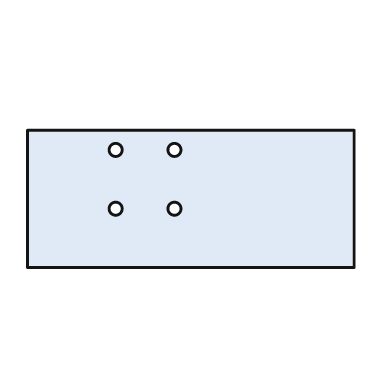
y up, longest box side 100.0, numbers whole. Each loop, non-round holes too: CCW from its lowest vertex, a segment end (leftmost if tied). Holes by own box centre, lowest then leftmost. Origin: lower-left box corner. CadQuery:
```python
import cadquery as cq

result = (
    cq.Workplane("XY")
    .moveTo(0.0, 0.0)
    .lineTo(100.0, 0.0)
    .lineTo(100.0, 42.0)
    .lineTo(0.0, 42.0)
    .close()
    .moveTo(27.0, 18.0)
    .circle(2.0)
    .moveTo(45.0, 18.0)
    .circle(2.0)
    .moveTo(27.0, 36.0)
    .circle(2.0)
    .moveTo(45.0, 36.0)
    .circle(2.0)
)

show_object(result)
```